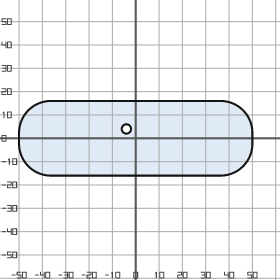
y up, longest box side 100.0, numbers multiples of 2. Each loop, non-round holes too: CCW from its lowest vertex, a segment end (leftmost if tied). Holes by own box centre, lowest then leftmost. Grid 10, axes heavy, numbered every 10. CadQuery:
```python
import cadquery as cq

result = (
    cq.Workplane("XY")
    .moveTo(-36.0, -16.0)
    .lineTo(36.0, -16.0)
    .threePointArc((46.0, -12.0), (50.0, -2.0))
    .lineTo(50.0, 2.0)
    .threePointArc((46.0, 12.0), (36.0, 16.0))
    .lineTo(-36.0, 16.0)
    .threePointArc((-46.0, 12.0), (-50.0, 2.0))
    .lineTo(-50.0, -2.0)
    .threePointArc((-46.0, -12.0), (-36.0, -16.0))
    .close()
    .moveTo(-4.0, 4.0)
    .circle(2.0)
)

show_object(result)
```